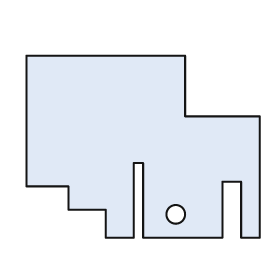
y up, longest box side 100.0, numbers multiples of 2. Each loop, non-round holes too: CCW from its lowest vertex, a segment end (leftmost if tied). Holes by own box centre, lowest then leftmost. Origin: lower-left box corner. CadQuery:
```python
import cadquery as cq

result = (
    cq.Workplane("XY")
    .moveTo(34.0, 0.0)
    .lineTo(46.0, 0.0)
    .lineTo(46.0, 32.0)
    .lineTo(50.0, 32.0)
    .lineTo(50.0, 0.0)
    .lineTo(84.0, 0.0)
    .lineTo(84.0, 24.0)
    .lineTo(92.0, 24.0)
    .lineTo(92.0, 0.0)
    .lineTo(100.0, 0.0)
    .lineTo(100.0, 52.0)
    .lineTo(68.0, 52.0)
    .lineTo(68.0, 78.0)
    .lineTo(0.0, 78.0)
    .lineTo(0.0, 22.0)
    .lineTo(18.0, 22.0)
    .lineTo(18.0, 12.0)
    .lineTo(34.0, 12.0)
    .close()
    .moveTo(64.0, 10.0)
    .circle(4.0)
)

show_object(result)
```